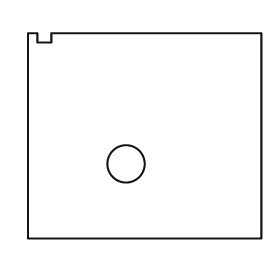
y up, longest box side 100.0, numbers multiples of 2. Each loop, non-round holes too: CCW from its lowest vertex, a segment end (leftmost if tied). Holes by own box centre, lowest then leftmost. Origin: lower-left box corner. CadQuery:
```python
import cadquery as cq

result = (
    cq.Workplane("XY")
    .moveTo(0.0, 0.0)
    .lineTo(100.0, 0.0)
    .lineTo(100.0, 88.0)
    .lineTo(10.0, 88.0)
    .lineTo(10.0, 84.0)
    .lineTo(4.0, 84.0)
    .lineTo(4.0, 88.0)
    .lineTo(0.0, 88.0)
    .close()
    .moveTo(42.0, 32.0)
    .circle(8.0)
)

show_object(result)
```